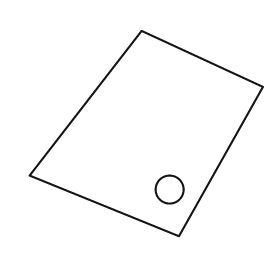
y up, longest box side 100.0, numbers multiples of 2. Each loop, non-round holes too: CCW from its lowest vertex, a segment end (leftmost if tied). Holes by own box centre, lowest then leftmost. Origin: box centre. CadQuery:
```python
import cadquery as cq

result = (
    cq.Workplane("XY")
    .moveTo(14.0, -44.0)
    .lineTo(50.0, 20.0)
    .lineTo(-2.0, 44.0)
    .lineTo(-50.0, -18.0)
    .close()
    .moveTo(10.0, -24.0)
    .circle(6.0)
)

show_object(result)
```